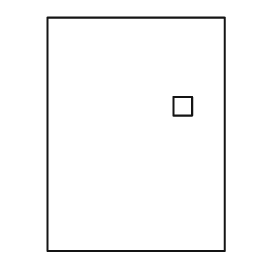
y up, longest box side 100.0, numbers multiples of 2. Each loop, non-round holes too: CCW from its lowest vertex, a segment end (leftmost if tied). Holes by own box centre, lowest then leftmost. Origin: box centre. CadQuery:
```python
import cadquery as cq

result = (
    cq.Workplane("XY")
    .moveTo(-38.0, -50.0)
    .lineTo(38.0, -50.0)
    .lineTo(38.0, 50.0)
    .lineTo(-38.0, 50.0)
    .close()
    .moveTo(16.0, 8.0)
    .lineTo(24.0, 8.0)
    .lineTo(24.0, 16.0)
    .lineTo(16.0, 16.0)
    .close()
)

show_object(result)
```